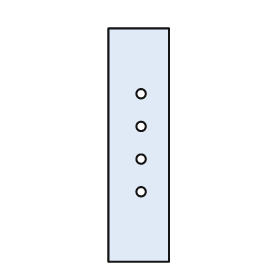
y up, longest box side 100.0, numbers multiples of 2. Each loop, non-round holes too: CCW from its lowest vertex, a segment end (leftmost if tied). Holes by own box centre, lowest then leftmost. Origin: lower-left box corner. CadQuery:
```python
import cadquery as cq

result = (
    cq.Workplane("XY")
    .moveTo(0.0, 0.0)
    .lineTo(26.0, 0.0)
    .lineTo(26.0, 100.0)
    .lineTo(0.0, 100.0)
    .close()
    .moveTo(14.0, 30.0)
    .circle(2.0)
    .moveTo(14.0, 44.0)
    .circle(2.0)
    .moveTo(14.0, 58.0)
    .circle(2.0)
    .moveTo(14.0, 72.0)
    .circle(2.0)
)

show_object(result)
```